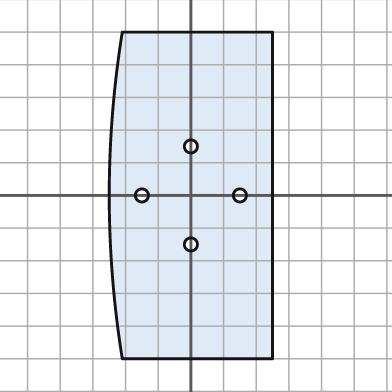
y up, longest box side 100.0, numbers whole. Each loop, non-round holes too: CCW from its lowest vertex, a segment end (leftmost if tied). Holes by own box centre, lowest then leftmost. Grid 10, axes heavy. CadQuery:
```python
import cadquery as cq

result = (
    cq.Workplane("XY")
    .moveTo(-21.0, -50.0)
    .lineTo(25.0, -50.0)
    .lineTo(25.0, 50.0)
    .lineTo(-21.0, 50.0)
    .threePointArc((-25.0, 0.0), (-21.0, -50.0))
    .close()
    .moveTo(0.0, -15.0)
    .circle(2.0)
    .moveTo(-15.0, 0.0)
    .circle(2.0)
    .moveTo(15.0, 0.0)
    .circle(2.0)
    .moveTo(0.0, 15.0)
    .circle(2.0)
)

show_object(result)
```